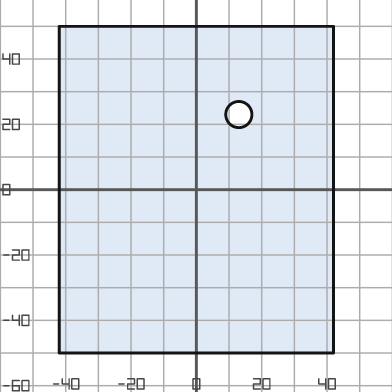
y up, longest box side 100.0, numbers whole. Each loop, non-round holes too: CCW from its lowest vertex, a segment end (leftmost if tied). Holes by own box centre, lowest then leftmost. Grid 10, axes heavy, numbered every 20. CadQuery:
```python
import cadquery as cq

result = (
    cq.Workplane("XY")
    .moveTo(-42.0, -50.0)
    .lineTo(42.0, -50.0)
    .lineTo(42.0, 50.0)
    .lineTo(-42.0, 50.0)
    .close()
    .moveTo(13.0, 23.0)
    .circle(4.0)
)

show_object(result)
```